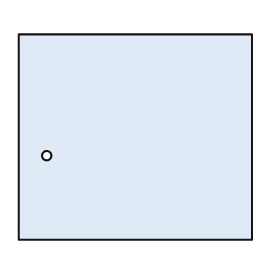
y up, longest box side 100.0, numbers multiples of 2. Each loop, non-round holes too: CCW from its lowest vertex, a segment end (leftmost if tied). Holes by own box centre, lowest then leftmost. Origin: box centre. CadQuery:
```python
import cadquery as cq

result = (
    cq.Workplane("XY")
    .moveTo(-50.0, -44.0)
    .lineTo(50.0, -44.0)
    .lineTo(50.0, 44.0)
    .lineTo(-50.0, 44.0)
    .close()
    .moveTo(-38.0, -8.0)
    .circle(2.0)
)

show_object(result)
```